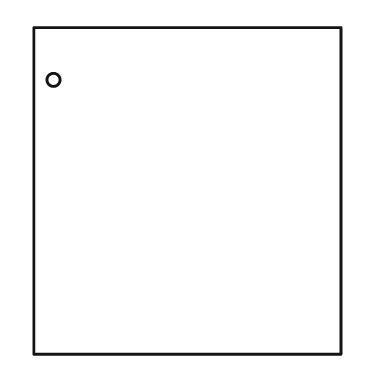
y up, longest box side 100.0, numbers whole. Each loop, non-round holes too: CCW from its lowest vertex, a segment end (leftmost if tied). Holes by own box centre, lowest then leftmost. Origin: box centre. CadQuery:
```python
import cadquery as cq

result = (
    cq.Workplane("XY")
    .moveTo(-47.0, -50.0)
    .lineTo(47.0, -50.0)
    .lineTo(47.0, 50.0)
    .lineTo(-47.0, 50.0)
    .close()
    .moveTo(-41.0, 34.0)
    .circle(2.0)
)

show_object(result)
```